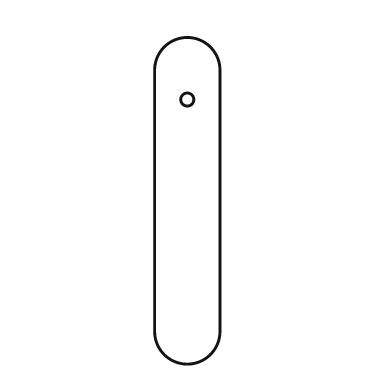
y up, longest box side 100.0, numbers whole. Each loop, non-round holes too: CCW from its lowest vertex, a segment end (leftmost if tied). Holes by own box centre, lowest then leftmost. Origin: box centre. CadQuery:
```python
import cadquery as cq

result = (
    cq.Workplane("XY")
    .moveTo(-10.0, -40.0)
    .threePointArc((0.0, -50.0), (10.0, -40.0))
    .lineTo(10.0, 40.0)
    .threePointArc((0.0, 50.0), (-10.0, 40.0))
    .close()
    .moveTo(0.0, 31.0)
    .circle(2.0)
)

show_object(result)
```